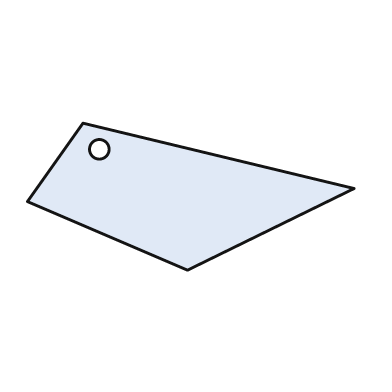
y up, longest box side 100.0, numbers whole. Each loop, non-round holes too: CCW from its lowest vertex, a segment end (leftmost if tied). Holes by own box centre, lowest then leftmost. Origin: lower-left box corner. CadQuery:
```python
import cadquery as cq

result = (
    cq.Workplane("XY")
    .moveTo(49.0, 0.0)
    .lineTo(100.0, 25.0)
    .lineTo(17.0, 45.0)
    .lineTo(0.0, 21.0)
    .close()
    .moveTo(22.0, 37.0)
    .circle(3.0)
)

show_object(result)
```